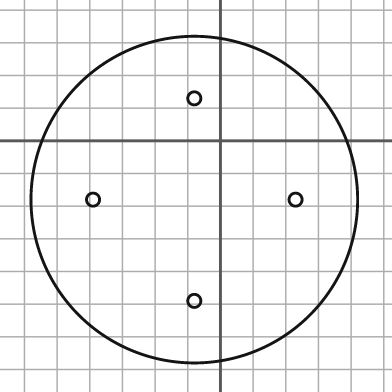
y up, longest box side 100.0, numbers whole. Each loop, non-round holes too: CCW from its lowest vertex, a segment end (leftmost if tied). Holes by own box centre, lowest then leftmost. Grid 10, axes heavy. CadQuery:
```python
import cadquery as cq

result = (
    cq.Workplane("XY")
    .moveTo(-8.0, -18.0)
    .circle(50.0)
    .moveTo(-8.0, -49.0)
    .circle(2.0)
    .moveTo(-39.0, -18.0)
    .circle(2.0)
    .moveTo(23.0, -18.0)
    .circle(2.0)
    .moveTo(-8.0, 13.0)
    .circle(2.0)
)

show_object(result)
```